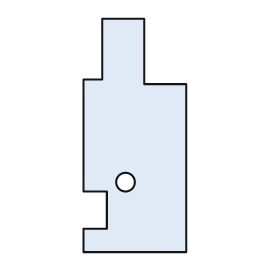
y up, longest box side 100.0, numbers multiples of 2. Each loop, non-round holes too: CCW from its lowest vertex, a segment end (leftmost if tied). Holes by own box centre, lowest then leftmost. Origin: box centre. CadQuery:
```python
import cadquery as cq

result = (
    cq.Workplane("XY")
    .moveTo(-22.0, -50.0)
    .lineTo(22.0, -50.0)
    .lineTo(22.0, 22.0)
    .lineTo(4.0, 22.0)
    .lineTo(4.0, 50.0)
    .lineTo(-14.0, 50.0)
    .lineTo(-14.0, 24.0)
    .lineTo(-22.0, 24.0)
    .lineTo(-22.0, -24.0)
    .lineTo(-12.0, -24.0)
    .lineTo(-12.0, -40.0)
    .lineTo(-22.0, -40.0)
    .close()
    .moveTo(-4.0, -20.0)
    .circle(4.0)
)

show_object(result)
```